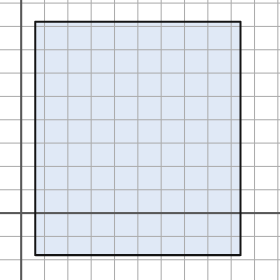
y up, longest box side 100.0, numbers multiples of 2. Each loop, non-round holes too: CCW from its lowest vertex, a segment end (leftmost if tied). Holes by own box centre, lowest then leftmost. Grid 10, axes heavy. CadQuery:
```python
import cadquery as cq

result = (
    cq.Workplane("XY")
    .moveTo(6.0, -18.0)
    .lineTo(94.0, -18.0)
    .lineTo(94.0, 82.0)
    .lineTo(6.0, 82.0)
    .close()
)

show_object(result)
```